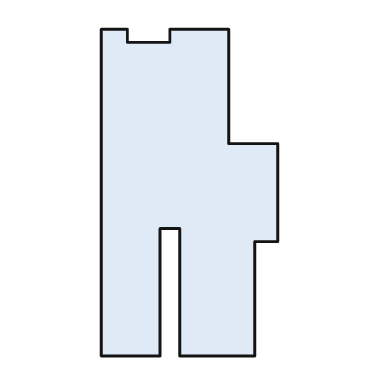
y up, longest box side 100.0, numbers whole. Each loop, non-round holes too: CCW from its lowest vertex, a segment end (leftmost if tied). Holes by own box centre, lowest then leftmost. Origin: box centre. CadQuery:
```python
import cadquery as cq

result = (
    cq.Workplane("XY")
    .moveTo(-27.0, -50.0)
    .lineTo(-9.0, -50.0)
    .lineTo(-9.0, -11.0)
    .lineTo(-3.0, -11.0)
    .lineTo(-3.0, -50.0)
    .lineTo(20.0, -50.0)
    .lineTo(20.0, -15.0)
    .lineTo(27.0, -15.0)
    .lineTo(27.0, 15.0)
    .lineTo(12.0, 15.0)
    .lineTo(12.0, 50.0)
    .lineTo(-6.0, 50.0)
    .lineTo(-6.0, 46.0)
    .lineTo(-19.0, 46.0)
    .lineTo(-19.0, 50.0)
    .lineTo(-27.0, 50.0)
    .close()
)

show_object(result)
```